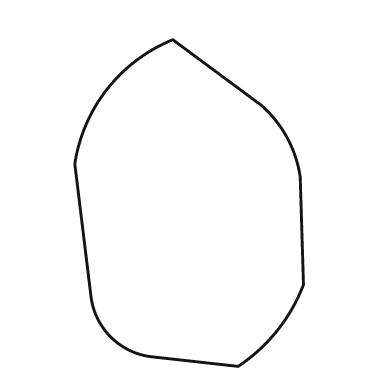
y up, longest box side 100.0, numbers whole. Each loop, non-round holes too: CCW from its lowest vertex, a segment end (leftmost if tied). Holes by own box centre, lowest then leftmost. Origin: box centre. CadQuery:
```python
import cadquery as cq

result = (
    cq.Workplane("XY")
    .moveTo(15.0, -50.0)
    .threePointArc((27.0, -39.0), (35.0, -25.0))
    .lineTo(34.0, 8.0)
    .threePointArc((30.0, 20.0), (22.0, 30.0))
    .lineTo(-5.0, 50.0)
    .threePointArc((-25.0, 35.0), (-35.0, 12.0))
    .lineTo(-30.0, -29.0)
    .threePointArc((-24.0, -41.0), (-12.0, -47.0))
    .close()
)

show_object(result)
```